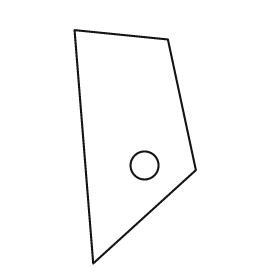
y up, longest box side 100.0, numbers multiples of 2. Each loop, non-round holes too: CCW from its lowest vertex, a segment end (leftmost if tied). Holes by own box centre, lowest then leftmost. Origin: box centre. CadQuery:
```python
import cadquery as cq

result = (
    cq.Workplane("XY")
    .moveTo(-18.0, -50.0)
    .lineTo(26.0, -10.0)
    .lineTo(14.0, 46.0)
    .lineTo(-26.0, 50.0)
    .close()
    .moveTo(4.0, -8.0)
    .circle(6.0)
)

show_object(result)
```